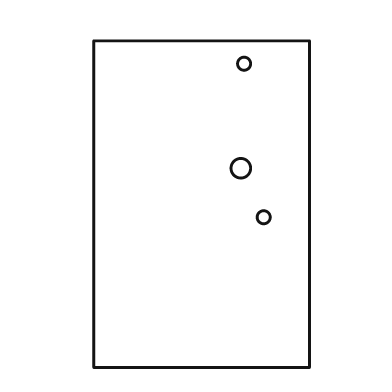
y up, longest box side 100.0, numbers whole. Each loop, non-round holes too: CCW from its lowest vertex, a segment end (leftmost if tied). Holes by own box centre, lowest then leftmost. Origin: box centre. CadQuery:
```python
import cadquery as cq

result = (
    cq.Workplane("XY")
    .moveTo(-33.0, -50.0)
    .lineTo(33.0, -50.0)
    .lineTo(33.0, 50.0)
    .lineTo(-33.0, 50.0)
    .close()
    .moveTo(19.0, -4.0)
    .circle(2.0)
    .moveTo(12.0, 11.0)
    .circle(3.0)
    .moveTo(13.0, 43.0)
    .circle(2.0)
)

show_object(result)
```